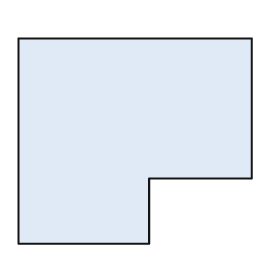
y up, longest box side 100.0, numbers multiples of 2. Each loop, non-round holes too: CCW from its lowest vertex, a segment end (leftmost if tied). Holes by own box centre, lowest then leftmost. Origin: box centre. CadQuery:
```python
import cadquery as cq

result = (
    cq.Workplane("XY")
    .moveTo(-50.0, -44.0)
    .lineTo(6.0, -44.0)
    .lineTo(6.0, -16.0)
    .lineTo(50.0, -16.0)
    .lineTo(50.0, 44.0)
    .lineTo(-50.0, 44.0)
    .close()
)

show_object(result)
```